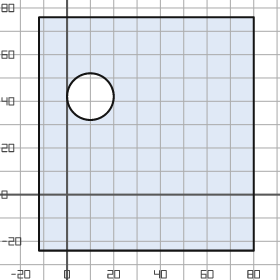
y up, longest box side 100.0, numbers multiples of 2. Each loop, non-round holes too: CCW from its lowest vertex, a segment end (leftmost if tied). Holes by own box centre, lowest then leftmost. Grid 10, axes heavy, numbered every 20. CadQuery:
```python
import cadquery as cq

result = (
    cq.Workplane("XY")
    .moveTo(-12.0, -24.0)
    .lineTo(80.0, -24.0)
    .lineTo(80.0, 76.0)
    .lineTo(-12.0, 76.0)
    .close()
    .moveTo(10.0, 42.0)
    .circle(10.0)
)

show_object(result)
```